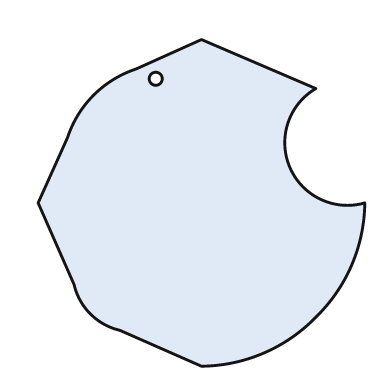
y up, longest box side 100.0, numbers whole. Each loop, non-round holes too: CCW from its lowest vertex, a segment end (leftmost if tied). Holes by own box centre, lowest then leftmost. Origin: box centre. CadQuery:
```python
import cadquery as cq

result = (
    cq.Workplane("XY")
    .moveTo(0.0, -50.0)
    .threePointArc((19.0, -46.0), (35.0, -35.0))
    .threePointArc((46.0, -19.0), (50.0, 0.0))
    .threePointArc((27.0, 11.0), (35.0, 35.0))
    .lineTo(0.0, 50.0)
    .lineTo(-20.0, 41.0)
    .threePointArc((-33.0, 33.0), (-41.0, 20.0))
    .lineTo(-50.0, 0.0)
    .lineTo(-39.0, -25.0)
    .threePointArc((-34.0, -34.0), (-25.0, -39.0))
    .close()
    .moveTo(-14.0, 38.0)
    .circle(2.0)
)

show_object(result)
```